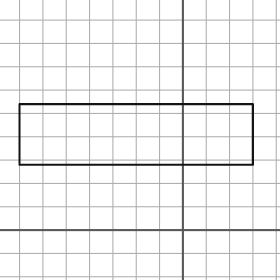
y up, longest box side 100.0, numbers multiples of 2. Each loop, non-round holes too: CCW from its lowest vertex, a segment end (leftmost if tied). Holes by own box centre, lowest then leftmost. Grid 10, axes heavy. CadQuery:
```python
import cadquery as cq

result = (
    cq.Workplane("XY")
    .moveTo(-70.0, 28.0)
    .lineTo(30.0, 28.0)
    .lineTo(30.0, 54.0)
    .lineTo(-70.0, 54.0)
    .close()
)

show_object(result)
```